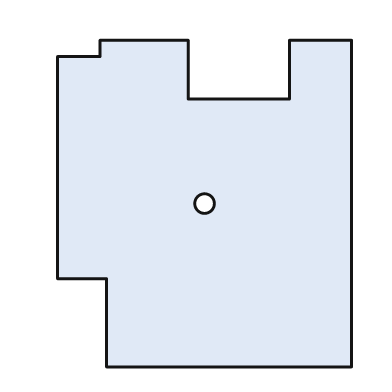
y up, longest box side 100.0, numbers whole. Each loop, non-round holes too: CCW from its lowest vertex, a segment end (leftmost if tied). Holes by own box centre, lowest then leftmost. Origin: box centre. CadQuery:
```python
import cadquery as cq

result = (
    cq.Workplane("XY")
    .moveTo(-30.0, -50.0)
    .lineTo(45.0, -50.0)
    .lineTo(45.0, 50.0)
    .lineTo(26.0, 50.0)
    .lineTo(26.0, 32.0)
    .lineTo(-5.0, 32.0)
    .lineTo(-5.0, 50.0)
    .lineTo(-32.0, 50.0)
    .lineTo(-32.0, 45.0)
    .lineTo(-45.0, 45.0)
    .lineTo(-45.0, -23.0)
    .lineTo(-30.0, -23.0)
    .close()
    .moveTo(0.0, 0.0)
    .circle(3.0)
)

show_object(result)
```